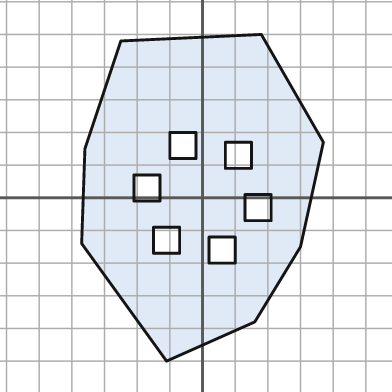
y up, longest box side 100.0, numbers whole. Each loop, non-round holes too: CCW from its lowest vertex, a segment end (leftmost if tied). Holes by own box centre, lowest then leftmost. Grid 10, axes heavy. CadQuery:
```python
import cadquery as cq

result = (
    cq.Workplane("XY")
    .moveTo(-11.0, -50.0)
    .lineTo(16.0, -38.0)
    .lineTo(30.0, -15.0)
    .lineTo(37.0, 17.0)
    .lineTo(18.0, 50.0)
    .lineTo(-25.0, 48.0)
    .lineTo(-36.0, 15.0)
    .lineTo(-37.0, -14.0)
    .close()
    .moveTo(2.0, -20.0)
    .lineTo(10.0, -20.0)
    .lineTo(10.0, -12.0)
    .lineTo(2.0, -12.0)
    .close()
    .moveTo(-15.0, -17.0)
    .lineTo(-7.0, -17.0)
    .lineTo(-7.0, -9.0)
    .lineTo(-15.0, -9.0)
    .close()
    .moveTo(13.0, -7.0)
    .lineTo(21.0, -7.0)
    .lineTo(21.0, 1.0)
    .lineTo(13.0, 1.0)
    .close()
    .moveTo(-21.0, -1.0)
    .lineTo(-13.0, -1.0)
    .lineTo(-13.0, 7.0)
    .lineTo(-21.0, 7.0)
    .close()
    .moveTo(7.0, 9.0)
    .lineTo(15.0, 9.0)
    .lineTo(15.0, 17.0)
    .lineTo(7.0, 17.0)
    .close()
    .moveTo(-10.0, 12.0)
    .lineTo(-2.0, 12.0)
    .lineTo(-2.0, 20.0)
    .lineTo(-10.0, 20.0)
    .close()
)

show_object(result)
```